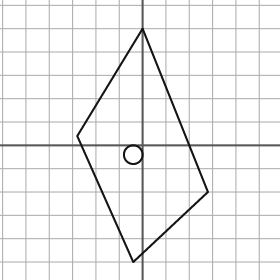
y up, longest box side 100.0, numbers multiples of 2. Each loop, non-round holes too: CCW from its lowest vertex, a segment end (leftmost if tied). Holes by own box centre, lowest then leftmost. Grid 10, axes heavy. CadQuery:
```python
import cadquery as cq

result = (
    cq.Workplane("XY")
    .moveTo(-4.0, -50.0)
    .lineTo(28.0, -20.0)
    .lineTo(0.0, 50.0)
    .lineTo(-28.0, 4.0)
    .close()
    .moveTo(-4.0, -4.0)
    .circle(4.0)
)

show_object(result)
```